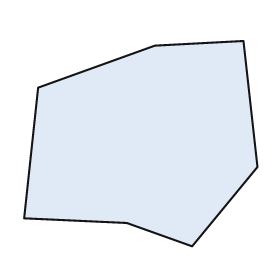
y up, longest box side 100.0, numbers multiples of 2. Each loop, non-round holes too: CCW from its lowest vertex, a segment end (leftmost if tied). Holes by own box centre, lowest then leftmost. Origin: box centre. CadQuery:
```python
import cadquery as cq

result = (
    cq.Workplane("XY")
    .moveTo(22.0, -44.0)
    .lineTo(50.0, -10.0)
    .lineTo(44.0, 44.0)
    .lineTo(6.0, 42.0)
    .lineTo(-44.0, 24.0)
    .lineTo(-50.0, -32.0)
    .lineTo(-6.0, -34.0)
    .close()
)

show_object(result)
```